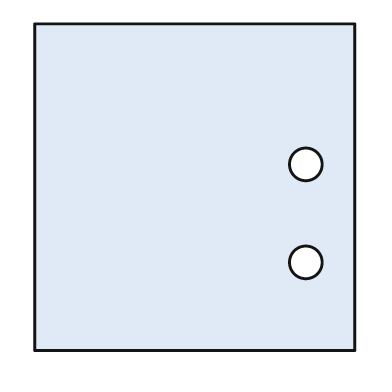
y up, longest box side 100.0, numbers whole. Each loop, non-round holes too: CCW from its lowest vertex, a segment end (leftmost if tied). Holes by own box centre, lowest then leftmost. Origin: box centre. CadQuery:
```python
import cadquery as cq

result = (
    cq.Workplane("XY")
    .moveTo(-49.0, -50.0)
    .lineTo(49.0, -50.0)
    .lineTo(49.0, 50.0)
    .lineTo(-49.0, 50.0)
    .close()
    .moveTo(34.0, -23.0)
    .circle(5.0)
    .moveTo(34.0, 7.0)
    .circle(5.0)
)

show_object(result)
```